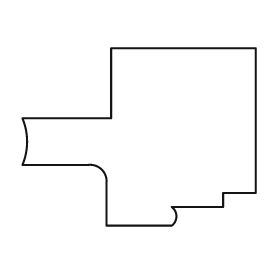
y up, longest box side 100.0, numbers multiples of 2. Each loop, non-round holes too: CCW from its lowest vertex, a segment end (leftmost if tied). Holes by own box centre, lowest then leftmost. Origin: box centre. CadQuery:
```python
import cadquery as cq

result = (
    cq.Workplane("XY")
    .moveTo(-14.0, -38.0)
    .lineTo(14.0, -38.0)
    .threePointArc((16.0, -34.0), (14.0, -30.0))
    .lineTo(36.0, -30.0)
    .lineTo(36.0, -24.0)
    .lineTo(50.0, -24.0)
    .lineTo(50.0, 38.0)
    .lineTo(-12.0, 38.0)
    .lineTo(-12.0, 8.0)
    .lineTo(-50.0, 8.0)
    .threePointArc((-48.0, -2.0), (-50.0, -12.0))
    .lineTo(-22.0, -12.0)
    .threePointArc((-16.0, -14.0), (-14.0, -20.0))
    .close()
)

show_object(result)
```